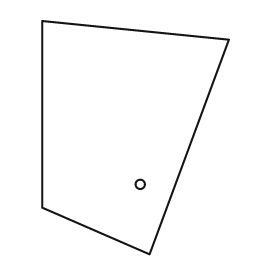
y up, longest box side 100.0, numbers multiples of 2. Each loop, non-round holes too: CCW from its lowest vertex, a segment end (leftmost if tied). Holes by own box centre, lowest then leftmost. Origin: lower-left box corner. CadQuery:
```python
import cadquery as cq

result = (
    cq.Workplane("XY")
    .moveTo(46.0, 0.0)
    .lineTo(80.0, 92.0)
    .lineTo(0.0, 100.0)
    .lineTo(0.0, 20.0)
    .close()
    .moveTo(42.0, 30.0)
    .circle(2.0)
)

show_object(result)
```